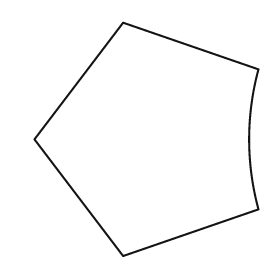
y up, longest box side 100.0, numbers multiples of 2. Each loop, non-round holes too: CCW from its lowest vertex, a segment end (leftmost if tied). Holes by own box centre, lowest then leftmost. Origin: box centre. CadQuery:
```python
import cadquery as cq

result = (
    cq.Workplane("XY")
    .moveTo(-10.0, -50.0)
    .lineTo(48.0, -30.0)
    .threePointArc((44.0, 0.0), (48.0, 30.0))
    .lineTo(-10.0, 50.0)
    .lineTo(-48.0, 0.0)
    .close()
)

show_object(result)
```